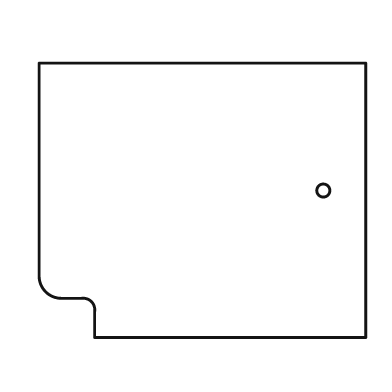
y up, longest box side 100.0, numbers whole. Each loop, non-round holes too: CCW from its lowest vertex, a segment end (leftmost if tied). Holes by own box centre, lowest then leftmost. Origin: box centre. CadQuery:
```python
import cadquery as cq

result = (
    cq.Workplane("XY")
    .moveTo(-33.0, -42.0)
    .lineTo(50.0, -42.0)
    .lineTo(50.0, 42.0)
    .lineTo(-50.0, 42.0)
    .lineTo(-50.0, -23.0)
    .threePointArc((-48.0, -28.0), (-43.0, -30.0))
    .lineTo(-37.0, -30.0)
    .threePointArc((-34.0, -31.0), (-33.0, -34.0))
    .close()
    .moveTo(37.0, 3.0)
    .circle(2.0)
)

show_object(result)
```